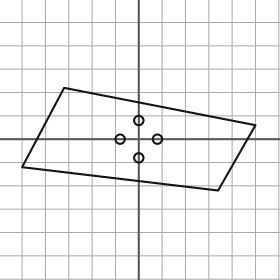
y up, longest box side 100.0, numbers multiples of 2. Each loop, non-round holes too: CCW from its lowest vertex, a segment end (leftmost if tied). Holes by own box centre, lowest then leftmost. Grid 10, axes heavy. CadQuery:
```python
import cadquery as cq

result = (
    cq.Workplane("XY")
    .moveTo(34.0, -22.0)
    .lineTo(50.0, 6.0)
    .lineTo(-32.0, 22.0)
    .lineTo(-50.0, -12.0)
    .close()
    .moveTo(0.0, -8.0)
    .circle(2.0)
    .moveTo(-8.0, 0.0)
    .circle(2.0)
    .moveTo(8.0, 0.0)
    .circle(2.0)
    .moveTo(0.0, 8.0)
    .circle(2.0)
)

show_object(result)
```